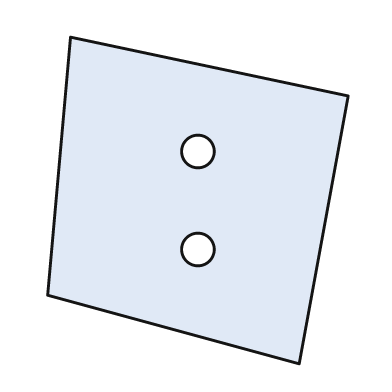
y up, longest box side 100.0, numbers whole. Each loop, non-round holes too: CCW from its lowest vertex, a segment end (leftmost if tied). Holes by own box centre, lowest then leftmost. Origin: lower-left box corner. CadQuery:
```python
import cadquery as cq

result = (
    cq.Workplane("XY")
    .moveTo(77.0, 0.0)
    .lineTo(92.0, 82.0)
    .lineTo(7.0, 100.0)
    .lineTo(0.0, 21.0)
    .close()
    .moveTo(46.0, 35.0)
    .circle(5.0)
    .moveTo(46.0, 65.0)
    .circle(5.0)
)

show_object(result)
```